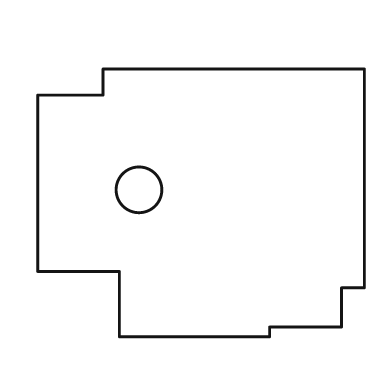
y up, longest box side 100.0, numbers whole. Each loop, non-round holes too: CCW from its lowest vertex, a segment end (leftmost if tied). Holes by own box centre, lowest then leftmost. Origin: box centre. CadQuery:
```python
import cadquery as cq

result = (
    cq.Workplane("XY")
    .moveTo(-25.0, -41.0)
    .lineTo(21.0, -41.0)
    .lineTo(21.0, -38.0)
    .lineTo(43.0, -38.0)
    .lineTo(43.0, -26.0)
    .lineTo(50.0, -26.0)
    .lineTo(50.0, 41.0)
    .lineTo(-30.0, 41.0)
    .lineTo(-30.0, 33.0)
    .lineTo(-50.0, 33.0)
    .lineTo(-50.0, -21.0)
    .lineTo(-25.0, -21.0)
    .close()
    .moveTo(-19.0, 4.0)
    .circle(7.0)
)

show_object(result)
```